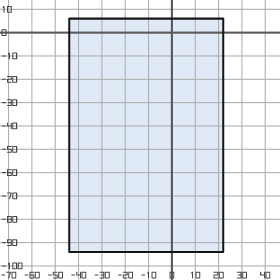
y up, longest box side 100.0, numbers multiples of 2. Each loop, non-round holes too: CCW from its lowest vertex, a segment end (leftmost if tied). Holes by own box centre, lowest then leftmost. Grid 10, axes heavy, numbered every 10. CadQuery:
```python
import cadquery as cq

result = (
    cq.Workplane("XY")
    .moveTo(-44.0, -94.0)
    .lineTo(22.0, -94.0)
    .lineTo(22.0, 6.0)
    .lineTo(-44.0, 6.0)
    .close()
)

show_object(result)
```